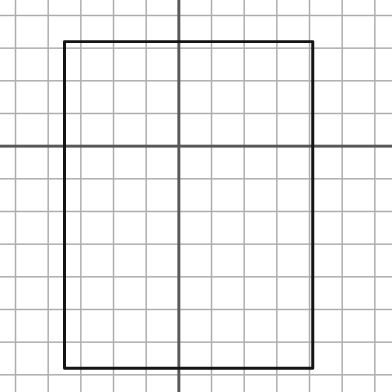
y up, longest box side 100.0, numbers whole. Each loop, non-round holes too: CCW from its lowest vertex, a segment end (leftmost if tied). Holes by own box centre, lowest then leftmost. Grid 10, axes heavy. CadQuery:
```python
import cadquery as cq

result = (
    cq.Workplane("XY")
    .moveTo(-35.0, -68.0)
    .lineTo(41.0, -68.0)
    .lineTo(41.0, 32.0)
    .lineTo(-35.0, 32.0)
    .close()
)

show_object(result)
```